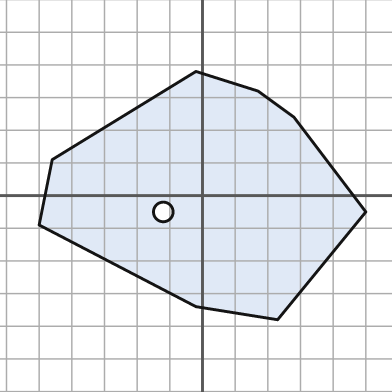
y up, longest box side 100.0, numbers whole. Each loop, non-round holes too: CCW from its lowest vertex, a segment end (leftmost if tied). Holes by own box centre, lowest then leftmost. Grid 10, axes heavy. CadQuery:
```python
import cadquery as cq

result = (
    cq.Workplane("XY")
    .moveTo(23.0, -38.0)
    .lineTo(50.0, -5.0)
    .lineTo(28.0, 24.0)
    .lineTo(17.0, 32.0)
    .lineTo(-2.0, 38.0)
    .lineTo(-46.0, 11.0)
    .lineTo(-50.0, -9.0)
    .lineTo(-2.0, -34.0)
    .close()
    .moveTo(-12.0, -5.0)
    .circle(3.0)
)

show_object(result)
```